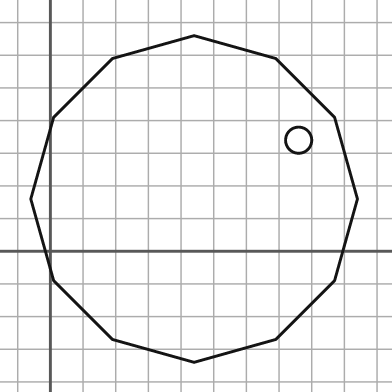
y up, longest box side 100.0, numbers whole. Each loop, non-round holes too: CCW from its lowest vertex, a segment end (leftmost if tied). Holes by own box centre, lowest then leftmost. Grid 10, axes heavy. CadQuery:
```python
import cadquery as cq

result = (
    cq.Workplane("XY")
    .moveTo(44.0, -34.0)
    .lineTo(69.0, -27.0)
    .lineTo(87.0, -9.0)
    .lineTo(94.0, 16.0)
    .lineTo(87.0, 41.0)
    .lineTo(69.0, 59.0)
    .lineTo(44.0, 66.0)
    .lineTo(19.0, 59.0)
    .lineTo(1.0, 41.0)
    .lineTo(-6.0, 16.0)
    .lineTo(1.0, -9.0)
    .lineTo(19.0, -27.0)
    .close()
    .moveTo(76.0, 34.0)
    .circle(4.0)
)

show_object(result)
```